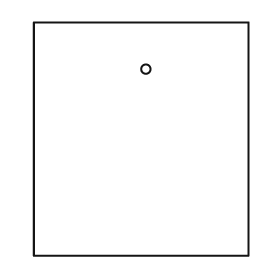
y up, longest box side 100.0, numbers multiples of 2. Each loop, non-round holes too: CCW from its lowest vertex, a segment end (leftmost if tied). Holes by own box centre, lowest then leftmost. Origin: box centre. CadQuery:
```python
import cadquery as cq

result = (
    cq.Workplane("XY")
    .moveTo(-46.0, -50.0)
    .lineTo(46.0, -50.0)
    .lineTo(46.0, 50.0)
    .lineTo(-46.0, 50.0)
    .close()
    .moveTo(2.0, 30.0)
    .circle(2.0)
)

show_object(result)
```